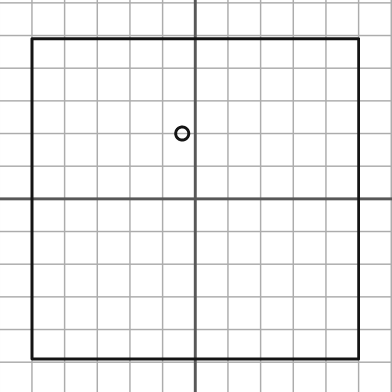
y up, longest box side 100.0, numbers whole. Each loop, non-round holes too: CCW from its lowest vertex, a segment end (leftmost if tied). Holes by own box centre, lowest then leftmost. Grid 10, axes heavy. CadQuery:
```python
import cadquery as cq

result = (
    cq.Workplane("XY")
    .moveTo(-50.0, -49.0)
    .lineTo(50.0, -49.0)
    .lineTo(50.0, 49.0)
    .lineTo(-50.0, 49.0)
    .close()
    .moveTo(-4.0, 20.0)
    .circle(2.0)
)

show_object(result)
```